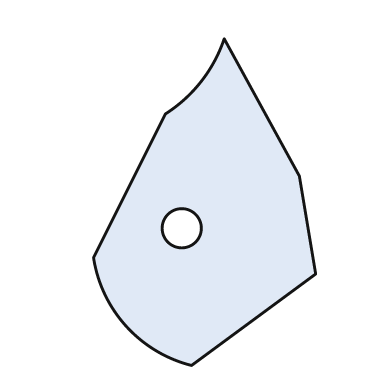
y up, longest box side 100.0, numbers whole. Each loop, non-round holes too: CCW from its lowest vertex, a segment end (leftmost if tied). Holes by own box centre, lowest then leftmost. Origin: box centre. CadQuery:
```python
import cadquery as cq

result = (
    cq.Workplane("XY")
    .moveTo(-4.0, -50.0)
    .lineTo(34.0, -22.0)
    .lineTo(29.0, 8.0)
    .lineTo(6.0, 50.0)
    .threePointArc((-1.0, 37.0), (-12.0, 27.0))
    .lineTo(-34.0, -17.0)
    .threePointArc((-24.0, -38.0), (-4.0, -50.0))
    .close()
    .moveTo(-7.0, -8.0)
    .circle(6.0)
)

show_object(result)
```